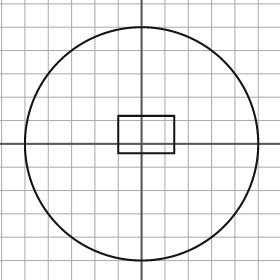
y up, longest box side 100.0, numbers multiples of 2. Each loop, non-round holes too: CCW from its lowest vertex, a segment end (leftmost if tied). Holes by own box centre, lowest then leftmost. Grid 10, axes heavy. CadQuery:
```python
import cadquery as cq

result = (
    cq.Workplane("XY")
    .moveTo(0.0, 0.0)
    .circle(50.0)
    .moveTo(-10.0, -4.0)
    .lineTo(14.0, -4.0)
    .lineTo(14.0, 12.0)
    .lineTo(-10.0, 12.0)
    .close()
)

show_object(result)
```